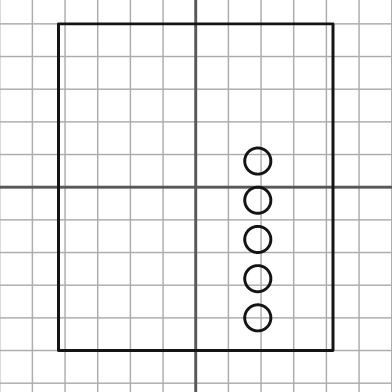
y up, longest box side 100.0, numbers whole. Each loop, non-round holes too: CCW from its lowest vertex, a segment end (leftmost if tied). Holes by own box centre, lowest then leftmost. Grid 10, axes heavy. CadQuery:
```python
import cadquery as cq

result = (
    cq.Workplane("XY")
    .moveTo(-42.0, -50.0)
    .lineTo(42.0, -50.0)
    .lineTo(42.0, 50.0)
    .lineTo(-42.0, 50.0)
    .close()
    .moveTo(19.0, -40.0)
    .circle(4.0)
    .moveTo(19.0, -28.0)
    .circle(4.0)
    .moveTo(19.0, -16.0)
    .circle(4.0)
    .moveTo(19.0, -4.0)
    .circle(4.0)
    .moveTo(19.0, 8.0)
    .circle(4.0)
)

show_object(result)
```